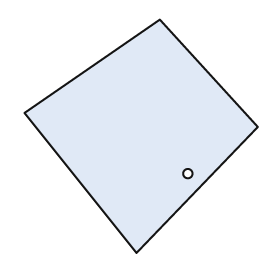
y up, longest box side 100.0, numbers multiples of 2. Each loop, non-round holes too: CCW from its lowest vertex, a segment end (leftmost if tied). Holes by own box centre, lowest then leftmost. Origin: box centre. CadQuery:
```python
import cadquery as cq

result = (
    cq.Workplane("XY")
    .moveTo(-2.0, -50.0)
    .lineTo(50.0, 4.0)
    .lineTo(8.0, 50.0)
    .lineTo(-50.0, 10.0)
    .close()
    .moveTo(20.0, -16.0)
    .circle(2.0)
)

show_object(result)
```